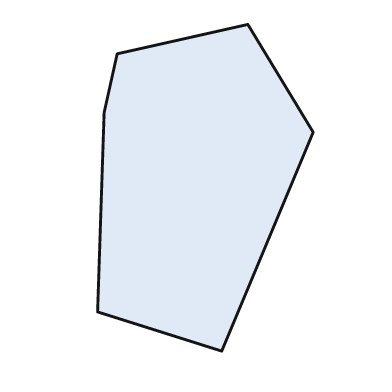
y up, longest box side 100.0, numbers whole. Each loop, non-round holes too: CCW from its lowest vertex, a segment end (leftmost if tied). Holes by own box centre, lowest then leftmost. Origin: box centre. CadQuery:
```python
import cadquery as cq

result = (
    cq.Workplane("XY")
    .moveTo(5.0, -50.0)
    .lineTo(33.0, 17.0)
    .lineTo(13.0, 50.0)
    .lineTo(-27.0, 41.0)
    .lineTo(-31.0, 23.0)
    .lineTo(-33.0, -38.0)
    .close()
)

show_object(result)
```